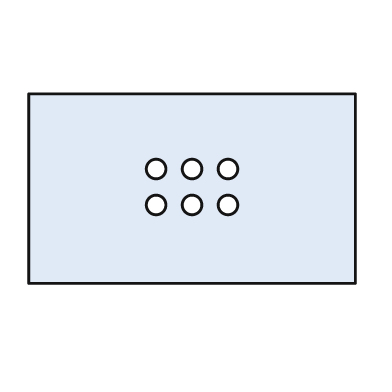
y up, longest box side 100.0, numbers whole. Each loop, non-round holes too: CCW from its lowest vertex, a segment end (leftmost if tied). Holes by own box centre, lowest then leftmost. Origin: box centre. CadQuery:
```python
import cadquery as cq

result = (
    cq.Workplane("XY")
    .moveTo(-50.0, -29.0)
    .lineTo(50.0, -29.0)
    .lineTo(50.0, 29.0)
    .lineTo(-50.0, 29.0)
    .close()
    .moveTo(-11.0, -5.0)
    .circle(3.0)
    .moveTo(0.0, -5.0)
    .circle(3.0)
    .moveTo(11.0, -5.0)
    .circle(3.0)
    .moveTo(-11.0, 6.0)
    .circle(3.0)
    .moveTo(0.0, 6.0)
    .circle(3.0)
    .moveTo(11.0, 6.0)
    .circle(3.0)
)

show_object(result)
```